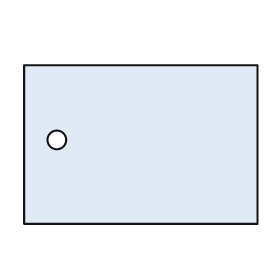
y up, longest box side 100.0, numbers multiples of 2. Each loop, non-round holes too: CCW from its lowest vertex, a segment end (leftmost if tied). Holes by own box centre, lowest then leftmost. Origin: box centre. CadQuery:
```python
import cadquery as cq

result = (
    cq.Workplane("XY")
    .moveTo(-50.0, -34.0)
    .lineTo(50.0, -34.0)
    .lineTo(50.0, 34.0)
    .lineTo(-50.0, 34.0)
    .close()
    .moveTo(-36.0, 2.0)
    .circle(4.0)
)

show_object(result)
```